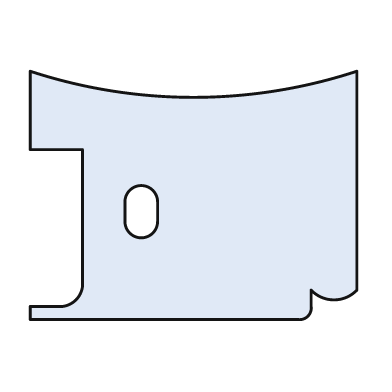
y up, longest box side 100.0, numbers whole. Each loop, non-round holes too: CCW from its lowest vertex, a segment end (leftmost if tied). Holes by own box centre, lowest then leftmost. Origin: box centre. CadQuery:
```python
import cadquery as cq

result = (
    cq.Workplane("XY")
    .moveTo(-50.0, -38.0)
    .lineTo(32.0, -38.0)
    .threePointArc((35.0, -37.0), (36.0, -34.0))
    .lineTo(36.0, -29.0)
    .threePointArc((43.0, -32.0), (50.0, -29.0))
    .lineTo(50.0, 38.0)
    .threePointArc((0.0, 30.0), (-50.0, 38.0))
    .lineTo(-50.0, 14.0)
    .lineTo(-34.0, 14.0)
    .lineTo(-34.0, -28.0)
    .threePointArc((-36.0, -32.0), (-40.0, -34.0))
    .lineTo(-50.0, -34.0)
    .close()
    .moveTo(-21.0, -8.0)
    .threePointArc((-16.0, -13.0), (-11.0, -8.0))
    .lineTo(-11.0, -2.0)
    .threePointArc((-16.0, 3.0), (-21.0, -2.0))
    .close()
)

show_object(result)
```